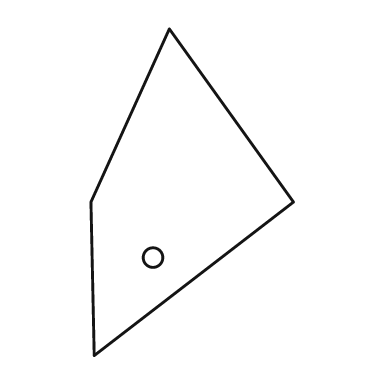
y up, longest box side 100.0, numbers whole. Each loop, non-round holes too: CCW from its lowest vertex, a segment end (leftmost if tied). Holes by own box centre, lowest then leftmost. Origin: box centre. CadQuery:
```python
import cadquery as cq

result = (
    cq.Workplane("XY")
    .moveTo(-30.0, -50.0)
    .lineTo(31.0, -3.0)
    .lineTo(-7.0, 50.0)
    .lineTo(-31.0, -3.0)
    .close()
    .moveTo(-12.0, -20.0)
    .circle(3.0)
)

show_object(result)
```